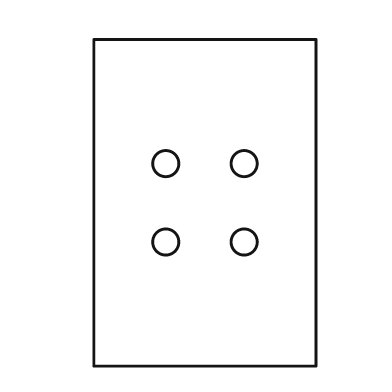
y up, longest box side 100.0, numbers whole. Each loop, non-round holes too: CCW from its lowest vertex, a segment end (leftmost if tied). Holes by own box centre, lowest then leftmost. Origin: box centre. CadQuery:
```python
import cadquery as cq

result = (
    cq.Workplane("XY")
    .moveTo(-34.0, -50.0)
    .lineTo(34.0, -50.0)
    .lineTo(34.0, 50.0)
    .lineTo(-34.0, 50.0)
    .close()
    .moveTo(-12.0, -12.0)
    .circle(4.0)
    .moveTo(12.0, -12.0)
    .circle(4.0)
    .moveTo(-12.0, 12.0)
    .circle(4.0)
    .moveTo(12.0, 12.0)
    .circle(4.0)
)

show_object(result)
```